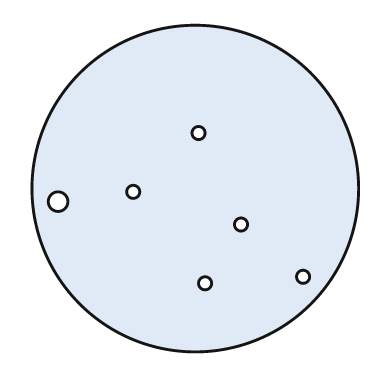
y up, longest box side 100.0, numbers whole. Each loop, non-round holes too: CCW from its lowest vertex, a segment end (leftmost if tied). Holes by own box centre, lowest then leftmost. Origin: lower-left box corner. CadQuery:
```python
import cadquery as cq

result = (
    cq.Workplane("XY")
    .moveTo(50.0, 50.0)
    .circle(50.0)
    .moveTo(53.0, 21.0)
    .circle(2.0)
    .moveTo(83.0, 23.0)
    .circle(2.0)
    .moveTo(64.0, 39.0)
    .circle(2.0)
    .moveTo(8.0, 46.0)
    .circle(3.0)
    .moveTo(31.0, 49.0)
    .circle(2.0)
    .moveTo(51.0, 67.0)
    .circle(2.0)
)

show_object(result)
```